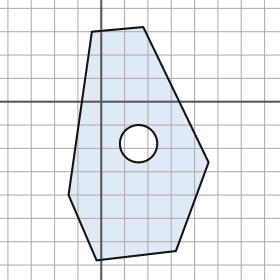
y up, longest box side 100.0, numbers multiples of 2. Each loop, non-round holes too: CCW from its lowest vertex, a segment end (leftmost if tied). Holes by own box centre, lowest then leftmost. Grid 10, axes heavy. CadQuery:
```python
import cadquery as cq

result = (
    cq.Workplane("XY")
    .moveTo(-2.0, -68.0)
    .lineTo(32.0, -64.0)
    .lineTo(46.0, -26.0)
    .lineTo(18.0, 32.0)
    .lineTo(-4.0, 30.0)
    .lineTo(-14.0, -40.0)
    .close()
    .moveTo(16.0, -18.0)
    .circle(8.0)
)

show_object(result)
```